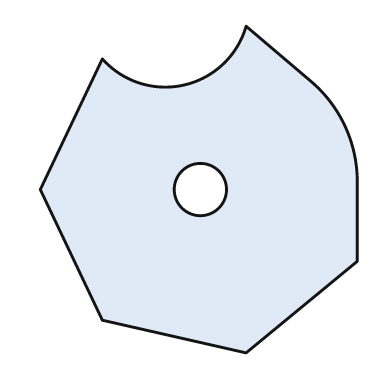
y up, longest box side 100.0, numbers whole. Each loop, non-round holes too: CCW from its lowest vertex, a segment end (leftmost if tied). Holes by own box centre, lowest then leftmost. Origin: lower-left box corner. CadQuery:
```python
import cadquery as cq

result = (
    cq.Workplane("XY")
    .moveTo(63.0, 0.0)
    .lineTo(97.0, 28.0)
    .lineTo(97.0, 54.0)
    .threePointArc((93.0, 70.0), (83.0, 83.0))
    .lineTo(63.0, 100.0)
    .threePointArc((44.0, 82.0), (19.0, 90.0))
    .lineTo(0.0, 50.0)
    .lineTo(19.0, 10.0)
    .close()
    .moveTo(49.0, 50.0)
    .circle(8.0)
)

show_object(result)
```